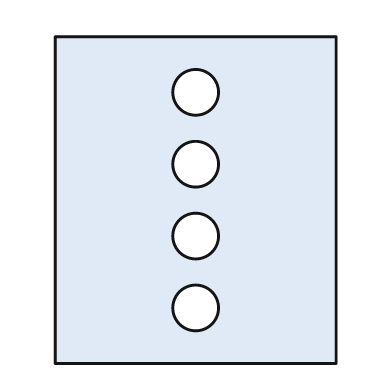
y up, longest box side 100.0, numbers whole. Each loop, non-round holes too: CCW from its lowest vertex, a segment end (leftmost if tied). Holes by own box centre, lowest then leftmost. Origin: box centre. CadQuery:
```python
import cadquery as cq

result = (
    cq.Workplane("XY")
    .moveTo(-43.0, -50.0)
    .lineTo(43.0, -50.0)
    .lineTo(43.0, 50.0)
    .lineTo(-43.0, 50.0)
    .close()
    .moveTo(0.0, -33.0)
    .circle(7.0)
    .moveTo(0.0, -11.0)
    .circle(7.0)
    .moveTo(0.0, 11.0)
    .circle(7.0)
    .moveTo(0.0, 33.0)
    .circle(7.0)
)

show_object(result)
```